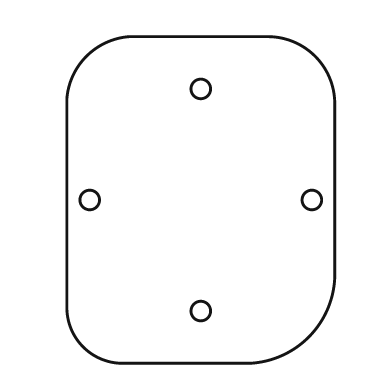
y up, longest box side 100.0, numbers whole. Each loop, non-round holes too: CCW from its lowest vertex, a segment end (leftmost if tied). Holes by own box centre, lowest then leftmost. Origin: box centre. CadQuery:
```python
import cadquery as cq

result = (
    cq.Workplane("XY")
    .moveTo(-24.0, -50.0)
    .lineTo(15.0, -50.0)
    .threePointArc((33.0, -42.0), (41.0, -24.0))
    .lineTo(41.0, 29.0)
    .threePointArc((35.0, 44.0), (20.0, 50.0))
    .lineTo(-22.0, 50.0)
    .threePointArc((-35.0, 44.0), (-41.0, 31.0))
    .lineTo(-41.0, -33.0)
    .threePointArc((-36.0, -45.0), (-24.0, -50.0))
    .close()
    .moveTo(0.0, -34.0)
    .circle(3.0)
    .moveTo(-34.0, 0.0)
    .circle(3.0)
    .moveTo(34.0, 0.0)
    .circle(3.0)
    .moveTo(0.0, 34.0)
    .circle(3.0)
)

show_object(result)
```